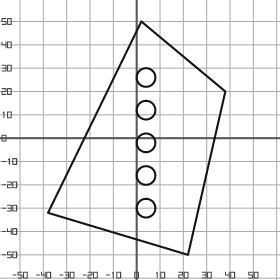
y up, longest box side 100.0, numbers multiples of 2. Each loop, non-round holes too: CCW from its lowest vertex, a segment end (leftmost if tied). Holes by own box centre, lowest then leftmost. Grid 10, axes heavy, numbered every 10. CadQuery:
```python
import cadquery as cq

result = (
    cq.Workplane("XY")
    .moveTo(22.0, -50.0)
    .lineTo(38.0, 20.0)
    .lineTo(2.0, 50.0)
    .lineTo(-38.0, -32.0)
    .close()
    .moveTo(4.0, -30.0)
    .circle(4.0)
    .moveTo(4.0, -16.0)
    .circle(4.0)
    .moveTo(4.0, -2.0)
    .circle(4.0)
    .moveTo(4.0, 12.0)
    .circle(4.0)
    .moveTo(4.0, 26.0)
    .circle(4.0)
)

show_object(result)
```